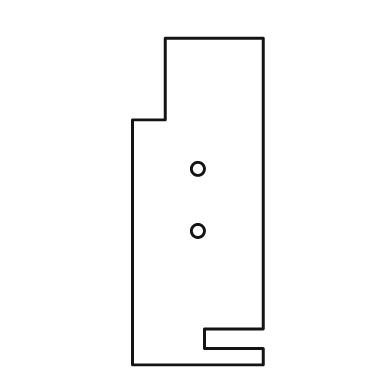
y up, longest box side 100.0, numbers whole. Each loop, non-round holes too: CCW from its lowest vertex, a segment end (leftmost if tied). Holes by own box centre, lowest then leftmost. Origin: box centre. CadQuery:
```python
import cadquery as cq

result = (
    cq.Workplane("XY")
    .moveTo(-20.0, -50.0)
    .lineTo(20.0, -50.0)
    .lineTo(20.0, -45.0)
    .lineTo(2.0, -45.0)
    .lineTo(2.0, -39.0)
    .lineTo(20.0, -39.0)
    .lineTo(20.0, 50.0)
    .lineTo(-10.0, 50.0)
    .lineTo(-10.0, 25.0)
    .lineTo(-20.0, 25.0)
    .close()
    .moveTo(0.0, -9.0)
    .circle(2.0)
    .moveTo(0.0, 10.0)
    .circle(2.0)
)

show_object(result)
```